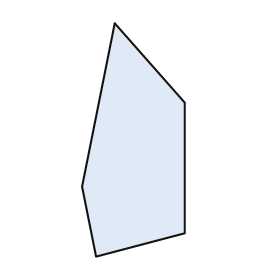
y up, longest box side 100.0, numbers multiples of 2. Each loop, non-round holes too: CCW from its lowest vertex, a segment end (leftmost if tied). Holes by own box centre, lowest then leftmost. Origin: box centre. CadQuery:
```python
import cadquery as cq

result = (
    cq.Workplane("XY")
    .moveTo(-16.0, -50.0)
    .lineTo(22.0, -40.0)
    .lineTo(22.0, 16.0)
    .lineTo(-8.0, 50.0)
    .lineTo(-22.0, -20.0)
    .close()
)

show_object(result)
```